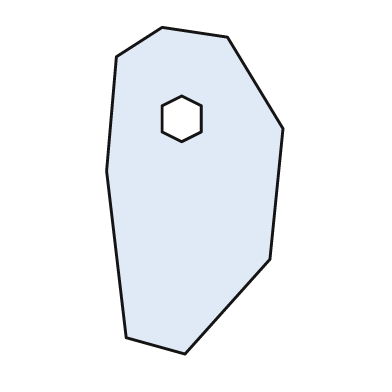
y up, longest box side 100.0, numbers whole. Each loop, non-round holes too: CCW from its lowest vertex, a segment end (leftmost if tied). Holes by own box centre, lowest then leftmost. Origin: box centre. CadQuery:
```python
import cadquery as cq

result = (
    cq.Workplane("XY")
    .moveTo(-3.0, -50.0)
    .lineTo(23.0, -21.0)
    .lineTo(27.0, 19.0)
    .lineTo(10.0, 47.0)
    .lineTo(-10.0, 50.0)
    .lineTo(-24.0, 41.0)
    .lineTo(-27.0, 6.0)
    .lineTo(-21.0, -45.0)
    .close()
    .moveTo(-4.0, 15.0)
    .lineTo(2.0, 18.0)
    .lineTo(2.0, 26.0)
    .lineTo(-4.0, 29.0)
    .lineTo(-10.0, 26.0)
    .lineTo(-10.0, 18.0)
    .close()
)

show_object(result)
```